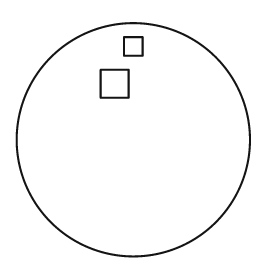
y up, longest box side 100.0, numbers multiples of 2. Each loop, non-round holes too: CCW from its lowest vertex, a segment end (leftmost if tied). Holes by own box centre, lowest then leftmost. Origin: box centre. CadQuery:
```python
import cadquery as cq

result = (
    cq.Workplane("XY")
    .moveTo(0.0, 0.0)
    .circle(50.0)
    .moveTo(-14.0, 18.0)
    .lineTo(-2.0, 18.0)
    .lineTo(-2.0, 30.0)
    .lineTo(-14.0, 30.0)
    .close()
    .moveTo(-4.0, 36.0)
    .lineTo(4.0, 36.0)
    .lineTo(4.0, 44.0)
    .lineTo(-4.0, 44.0)
    .close()
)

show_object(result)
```